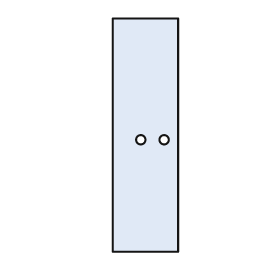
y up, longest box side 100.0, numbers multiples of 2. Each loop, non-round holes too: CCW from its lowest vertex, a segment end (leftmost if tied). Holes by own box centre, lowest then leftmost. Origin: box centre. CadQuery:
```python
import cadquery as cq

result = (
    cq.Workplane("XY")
    .moveTo(-14.0, -50.0)
    .lineTo(14.0, -50.0)
    .lineTo(14.0, 50.0)
    .lineTo(-14.0, 50.0)
    .close()
    .moveTo(-2.0, -2.0)
    .circle(2.0)
    .moveTo(8.0, -2.0)
    .circle(2.0)
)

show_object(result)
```